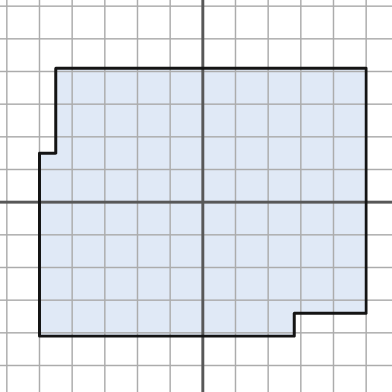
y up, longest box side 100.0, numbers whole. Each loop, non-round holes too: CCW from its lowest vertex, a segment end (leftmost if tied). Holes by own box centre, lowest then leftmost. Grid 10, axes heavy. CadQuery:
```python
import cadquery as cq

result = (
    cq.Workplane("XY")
    .moveTo(-50.0, -41.0)
    .lineTo(28.0, -41.0)
    .lineTo(28.0, -34.0)
    .lineTo(50.0, -34.0)
    .lineTo(50.0, 41.0)
    .lineTo(-45.0, 41.0)
    .lineTo(-45.0, 15.0)
    .lineTo(-50.0, 15.0)
    .close()
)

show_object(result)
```